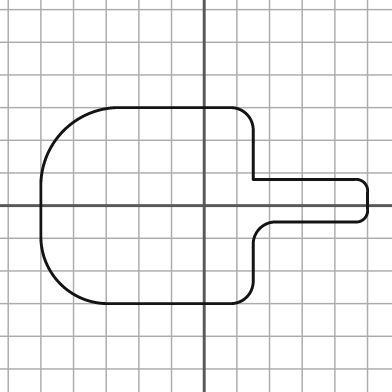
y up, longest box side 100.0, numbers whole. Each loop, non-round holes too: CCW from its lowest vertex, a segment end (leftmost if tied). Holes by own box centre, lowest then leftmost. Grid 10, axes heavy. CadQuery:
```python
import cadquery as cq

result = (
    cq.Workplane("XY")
    .moveTo(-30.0, -30.0)
    .lineTo(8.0, -30.0)
    .threePointArc((13.0, -28.0), (15.0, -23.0))
    .lineTo(15.0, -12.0)
    .threePointArc((17.0, -7.0), (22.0, -5.0))
    .lineTo(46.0, -5.0)
    .threePointArc((49.0, -4.0), (50.0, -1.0))
    .lineTo(50.0, 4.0)
    .threePointArc((49.0, 7.0), (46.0, 8.0))
    .lineTo(15.0, 8.0)
    .lineTo(15.0, 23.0)
    .threePointArc((13.0, 28.0), (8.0, 30.0))
    .lineTo(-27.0, 30.0)
    .threePointArc((-43.0, 23.0), (-50.0, 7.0))
    .lineTo(-50.0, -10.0)
    .threePointArc((-44.0, -24.0), (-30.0, -30.0))
    .close()
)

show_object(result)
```